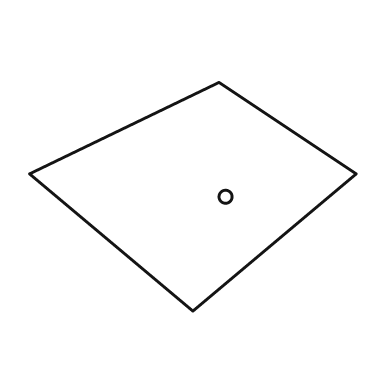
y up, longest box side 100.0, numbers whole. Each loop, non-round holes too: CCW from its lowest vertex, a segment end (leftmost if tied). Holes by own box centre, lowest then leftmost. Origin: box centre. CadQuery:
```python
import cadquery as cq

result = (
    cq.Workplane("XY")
    .moveTo(0.0, -35.0)
    .lineTo(50.0, 7.0)
    .lineTo(8.0, 35.0)
    .lineTo(-50.0, 7.0)
    .close()
    .moveTo(10.0, 0.0)
    .circle(2.0)
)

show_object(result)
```